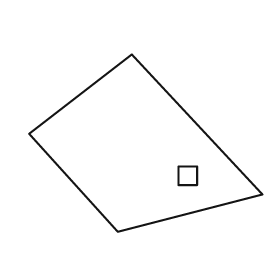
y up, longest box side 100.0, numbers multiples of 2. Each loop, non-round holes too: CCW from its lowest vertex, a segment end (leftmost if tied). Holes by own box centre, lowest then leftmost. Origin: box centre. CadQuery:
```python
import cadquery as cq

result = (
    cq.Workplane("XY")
    .moveTo(-12.0, -38.0)
    .lineTo(50.0, -22.0)
    .lineTo(-6.0, 38.0)
    .lineTo(-50.0, 4.0)
    .close()
    .moveTo(14.0, -18.0)
    .lineTo(22.0, -18.0)
    .lineTo(22.0, -10.0)
    .lineTo(14.0, -10.0)
    .close()
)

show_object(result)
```